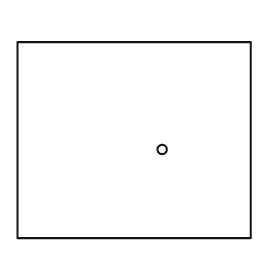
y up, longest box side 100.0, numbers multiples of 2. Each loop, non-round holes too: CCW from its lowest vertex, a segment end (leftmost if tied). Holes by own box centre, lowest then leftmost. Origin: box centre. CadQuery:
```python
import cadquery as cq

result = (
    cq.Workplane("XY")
    .moveTo(-50.0, -42.0)
    .lineTo(50.0, -42.0)
    .lineTo(50.0, 42.0)
    .lineTo(-50.0, 42.0)
    .close()
    .moveTo(12.0, -4.0)
    .circle(2.0)
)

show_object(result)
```